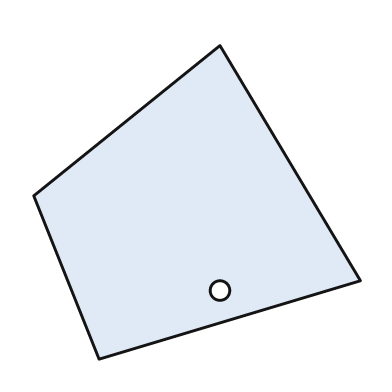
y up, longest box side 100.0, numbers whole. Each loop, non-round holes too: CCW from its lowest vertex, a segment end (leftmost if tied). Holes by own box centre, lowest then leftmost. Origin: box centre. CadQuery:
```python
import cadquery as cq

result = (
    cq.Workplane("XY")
    .moveTo(-30.0, -48.0)
    .lineTo(50.0, -24.0)
    .lineTo(7.0, 48.0)
    .lineTo(-50.0, 2.0)
    .close()
    .moveTo(7.0, -27.0)
    .circle(3.0)
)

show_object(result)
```